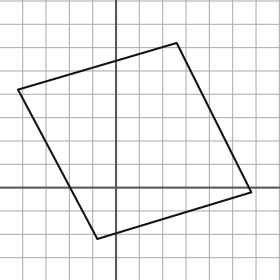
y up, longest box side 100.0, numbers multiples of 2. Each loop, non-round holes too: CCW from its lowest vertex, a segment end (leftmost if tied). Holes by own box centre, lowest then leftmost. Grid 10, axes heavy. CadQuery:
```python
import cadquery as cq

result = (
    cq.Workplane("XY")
    .moveTo(-8.0, -22.0)
    .lineTo(58.0, -2.0)
    .lineTo(26.0, 62.0)
    .lineTo(-42.0, 42.0)
    .close()
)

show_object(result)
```